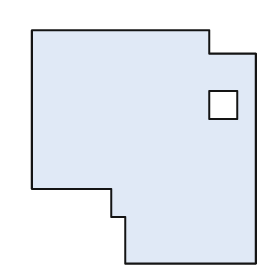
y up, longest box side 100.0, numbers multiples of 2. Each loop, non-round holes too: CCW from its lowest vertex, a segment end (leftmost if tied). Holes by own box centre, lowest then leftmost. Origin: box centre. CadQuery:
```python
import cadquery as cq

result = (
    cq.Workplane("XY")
    .moveTo(-8.0, -50.0)
    .lineTo(48.0, -50.0)
    .lineTo(48.0, 40.0)
    .lineTo(28.0, 40.0)
    .lineTo(28.0, 50.0)
    .lineTo(-48.0, 50.0)
    .lineTo(-48.0, -18.0)
    .lineTo(-14.0, -18.0)
    .lineTo(-14.0, -30.0)
    .lineTo(-8.0, -30.0)
    .close()
    .moveTo(28.0, 12.0)
    .lineTo(40.0, 12.0)
    .lineTo(40.0, 24.0)
    .lineTo(28.0, 24.0)
    .close()
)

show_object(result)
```